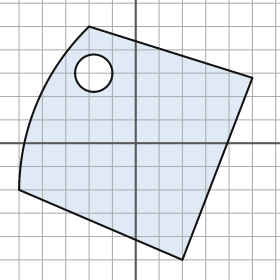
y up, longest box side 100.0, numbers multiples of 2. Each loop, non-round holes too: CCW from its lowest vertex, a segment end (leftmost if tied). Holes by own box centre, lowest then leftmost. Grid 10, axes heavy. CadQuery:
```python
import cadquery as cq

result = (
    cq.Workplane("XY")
    .moveTo(20.0, -50.0)
    .lineTo(50.0, 28.0)
    .lineTo(-20.0, 50.0)
    .threePointArc((-42.0, 18.0), (-50.0, -20.0))
    .close()
    .moveTo(-18.0, 30.0)
    .circle(8.0)
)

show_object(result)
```